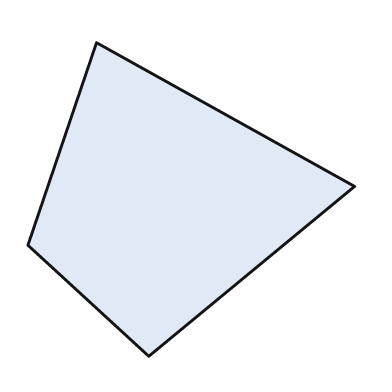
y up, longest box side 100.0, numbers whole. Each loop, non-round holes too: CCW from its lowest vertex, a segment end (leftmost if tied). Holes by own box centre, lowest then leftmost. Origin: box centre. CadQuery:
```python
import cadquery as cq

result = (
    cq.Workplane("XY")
    .moveTo(-13.0, -48.0)
    .lineTo(50.0, 4.0)
    .lineTo(-29.0, 48.0)
    .lineTo(-50.0, -14.0)
    .close()
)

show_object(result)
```